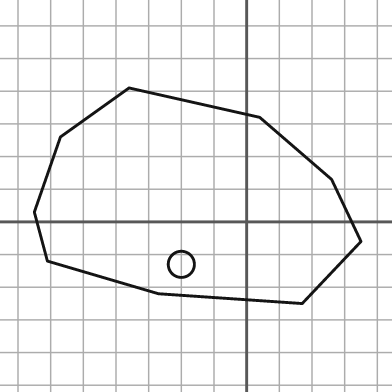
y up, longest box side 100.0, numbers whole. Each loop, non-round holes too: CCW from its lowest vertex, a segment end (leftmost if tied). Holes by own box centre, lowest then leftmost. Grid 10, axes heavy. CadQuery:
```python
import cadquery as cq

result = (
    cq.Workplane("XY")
    .moveTo(17.0, -25.0)
    .lineTo(35.0, -6.0)
    .lineTo(26.0, 13.0)
    .lineTo(4.0, 32.0)
    .lineTo(-36.0, 41.0)
    .lineTo(-57.0, 26.0)
    .lineTo(-65.0, 3.0)
    .lineTo(-61.0, -12.0)
    .lineTo(-27.0, -22.0)
    .close()
    .moveTo(-20.0, -13.0)
    .circle(4.0)
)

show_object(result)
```